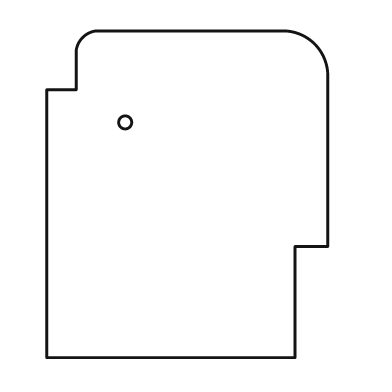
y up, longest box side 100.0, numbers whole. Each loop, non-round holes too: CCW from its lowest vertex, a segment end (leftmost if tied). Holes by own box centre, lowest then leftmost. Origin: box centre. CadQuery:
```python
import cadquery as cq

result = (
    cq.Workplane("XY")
    .moveTo(-43.0, -50.0)
    .lineTo(33.0, -50.0)
    .lineTo(33.0, -16.0)
    .lineTo(43.0, -16.0)
    .lineTo(43.0, 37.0)
    .threePointArc((39.0, 46.0), (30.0, 50.0))
    .lineTo(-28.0, 50.0)
    .threePointArc((-32.0, 48.0), (-34.0, 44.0))
    .lineTo(-34.0, 32.0)
    .lineTo(-43.0, 32.0)
    .close()
    .moveTo(-19.0, 22.0)
    .circle(2.0)
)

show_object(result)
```